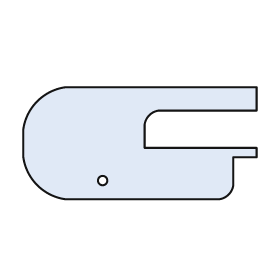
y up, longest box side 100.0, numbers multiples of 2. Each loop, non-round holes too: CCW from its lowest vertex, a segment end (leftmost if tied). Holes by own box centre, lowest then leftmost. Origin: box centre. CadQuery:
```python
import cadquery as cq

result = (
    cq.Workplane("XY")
    .moveTo(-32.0, -24.0)
    .lineTo(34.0, -24.0)
    .threePointArc((38.0, -22.0), (40.0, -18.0))
    .lineTo(40.0, -6.0)
    .lineTo(50.0, -6.0)
    .lineTo(50.0, -2.0)
    .lineTo(2.0, -2.0)
    .lineTo(2.0, 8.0)
    .threePointArc((4.0, 12.0), (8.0, 14.0))
    .lineTo(50.0, 14.0)
    .lineTo(50.0, 24.0)
    .lineTo(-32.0, 24.0)
    .threePointArc((-44.0, 18.0), (-50.0, 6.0))
    .lineTo(-50.0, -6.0)
    .threePointArc((-44.0, -18.0), (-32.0, -24.0))
    .close()
    .moveTo(-16.0, -16.0)
    .circle(2.0)
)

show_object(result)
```